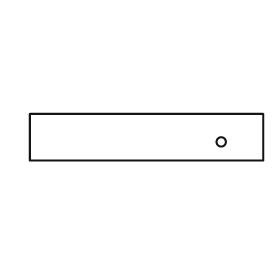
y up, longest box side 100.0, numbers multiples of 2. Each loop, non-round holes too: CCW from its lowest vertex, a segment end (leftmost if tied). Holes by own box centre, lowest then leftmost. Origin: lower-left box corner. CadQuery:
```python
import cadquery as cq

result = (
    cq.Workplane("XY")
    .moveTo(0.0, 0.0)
    .lineTo(100.0, 0.0)
    .lineTo(100.0, 20.0)
    .lineTo(0.0, 20.0)
    .close()
    .moveTo(82.0, 8.0)
    .circle(2.0)
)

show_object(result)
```